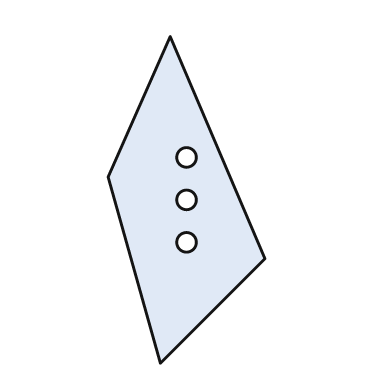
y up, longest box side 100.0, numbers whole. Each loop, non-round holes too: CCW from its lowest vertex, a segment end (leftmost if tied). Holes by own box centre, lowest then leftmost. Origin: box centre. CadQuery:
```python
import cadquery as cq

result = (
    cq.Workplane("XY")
    .moveTo(-8.0, -50.0)
    .lineTo(24.0, -18.0)
    .lineTo(-5.0, 50.0)
    .lineTo(-24.0, 7.0)
    .close()
    .moveTo(0.0, -13.0)
    .circle(3.0)
    .moveTo(0.0, 0.0)
    .circle(3.0)
    .moveTo(0.0, 13.0)
    .circle(3.0)
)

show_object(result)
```